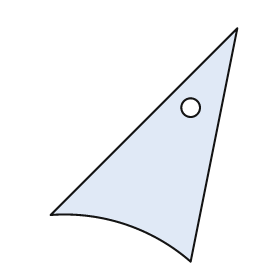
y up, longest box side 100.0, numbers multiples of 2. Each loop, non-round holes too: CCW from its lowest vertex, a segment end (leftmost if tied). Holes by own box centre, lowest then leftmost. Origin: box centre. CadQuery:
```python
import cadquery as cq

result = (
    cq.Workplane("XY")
    .moveTo(20.0, -50.0)
    .lineTo(40.0, 50.0)
    .lineTo(-40.0, -30.0)
    .threePointArc((-8.0, -34.0), (20.0, -50.0))
    .close()
    .moveTo(20.0, 16.0)
    .circle(4.0)
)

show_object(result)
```